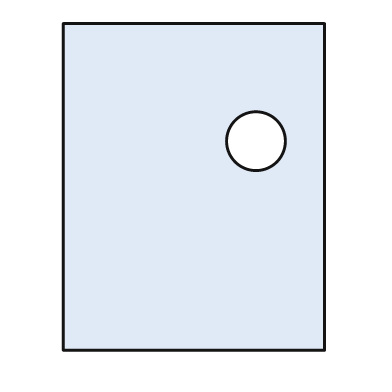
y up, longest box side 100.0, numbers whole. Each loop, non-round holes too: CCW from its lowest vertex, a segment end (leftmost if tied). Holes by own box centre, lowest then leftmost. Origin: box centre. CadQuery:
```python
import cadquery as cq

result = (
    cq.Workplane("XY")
    .moveTo(-40.0, -50.0)
    .lineTo(40.0, -50.0)
    .lineTo(40.0, 50.0)
    .lineTo(-40.0, 50.0)
    .close()
    .moveTo(19.0, 14.0)
    .circle(9.0)
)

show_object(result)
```